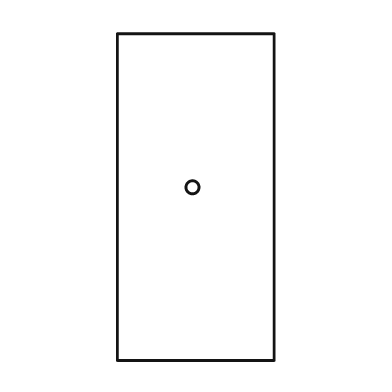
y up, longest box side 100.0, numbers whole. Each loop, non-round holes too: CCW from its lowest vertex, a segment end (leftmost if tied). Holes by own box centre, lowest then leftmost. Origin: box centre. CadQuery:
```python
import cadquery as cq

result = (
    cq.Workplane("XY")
    .moveTo(-24.0, -50.0)
    .lineTo(24.0, -50.0)
    .lineTo(24.0, 50.0)
    .lineTo(-24.0, 50.0)
    .close()
    .moveTo(-1.0, 3.0)
    .circle(2.0)
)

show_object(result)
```